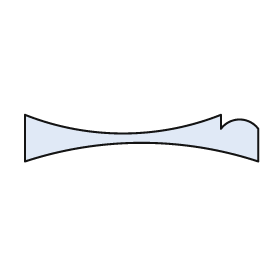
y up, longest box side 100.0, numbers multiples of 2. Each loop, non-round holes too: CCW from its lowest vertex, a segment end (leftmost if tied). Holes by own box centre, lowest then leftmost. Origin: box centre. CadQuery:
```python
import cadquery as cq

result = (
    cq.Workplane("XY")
    .moveTo(-50.0, -10.0)
    .threePointArc((0.0, -2.0), (50.0, -10.0))
    .lineTo(50.0, 4.0)
    .threePointArc((42.0, 8.0), (34.0, 4.0))
    .lineTo(34.0, 10.0)
    .threePointArc((-8.0, 2.0), (-50.0, 10.0))
    .close()
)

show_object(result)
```